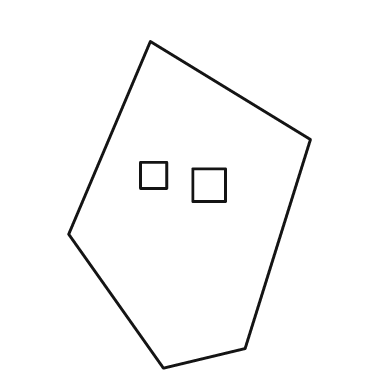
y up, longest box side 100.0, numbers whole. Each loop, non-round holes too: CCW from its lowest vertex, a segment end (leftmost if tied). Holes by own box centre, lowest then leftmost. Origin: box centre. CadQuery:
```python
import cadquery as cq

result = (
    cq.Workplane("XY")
    .moveTo(-8.0, -50.0)
    .lineTo(17.0, -44.0)
    .lineTo(37.0, 20.0)
    .lineTo(-12.0, 50.0)
    .lineTo(-37.0, -9.0)
    .close()
    .moveTo(1.0, 1.0)
    .lineTo(11.0, 1.0)
    .lineTo(11.0, 11.0)
    .lineTo(1.0, 11.0)
    .close()
    .moveTo(-15.0, 5.0)
    .lineTo(-7.0, 5.0)
    .lineTo(-7.0, 13.0)
    .lineTo(-15.0, 13.0)
    .close()
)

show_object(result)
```